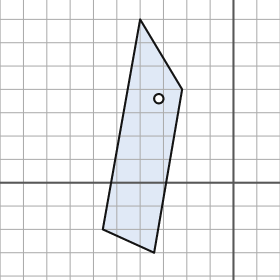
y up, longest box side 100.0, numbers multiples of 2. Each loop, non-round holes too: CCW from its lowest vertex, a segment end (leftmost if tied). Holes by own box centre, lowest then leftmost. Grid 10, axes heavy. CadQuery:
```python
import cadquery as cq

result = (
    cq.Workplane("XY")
    .moveTo(-34.0, -30.0)
    .lineTo(-22.0, 40.0)
    .lineTo(-40.0, 70.0)
    .lineTo(-56.0, -20.0)
    .close()
    .moveTo(-32.0, 36.0)
    .circle(2.0)
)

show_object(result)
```